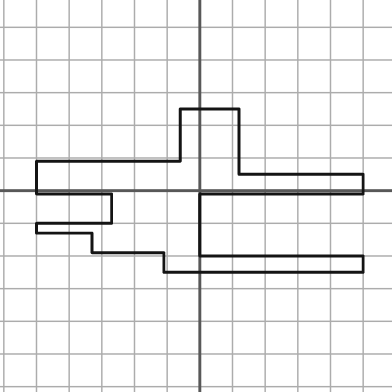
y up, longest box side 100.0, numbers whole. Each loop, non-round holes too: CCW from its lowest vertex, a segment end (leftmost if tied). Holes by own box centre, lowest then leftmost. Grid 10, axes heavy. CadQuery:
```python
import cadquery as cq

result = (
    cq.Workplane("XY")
    .moveTo(-11.0, -25.0)
    .lineTo(50.0, -25.0)
    .lineTo(50.0, -20.0)
    .lineTo(0.0, -20.0)
    .lineTo(0.0, -1.0)
    .lineTo(50.0, -1.0)
    .lineTo(50.0, 5.0)
    .lineTo(12.0, 5.0)
    .lineTo(12.0, 25.0)
    .lineTo(-6.0, 25.0)
    .lineTo(-6.0, 9.0)
    .lineTo(-50.0, 9.0)
    .lineTo(-50.0, -1.0)
    .lineTo(-27.0, -1.0)
    .lineTo(-27.0, -10.0)
    .lineTo(-50.0, -10.0)
    .lineTo(-50.0, -13.0)
    .lineTo(-33.0, -13.0)
    .lineTo(-33.0, -19.0)
    .lineTo(-11.0, -19.0)
    .close()
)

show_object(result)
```